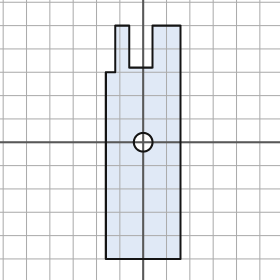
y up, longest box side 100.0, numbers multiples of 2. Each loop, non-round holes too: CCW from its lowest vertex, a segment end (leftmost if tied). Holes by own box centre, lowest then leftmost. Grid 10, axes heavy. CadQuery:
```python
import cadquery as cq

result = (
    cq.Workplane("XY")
    .moveTo(-16.0, -50.0)
    .lineTo(16.0, -50.0)
    .lineTo(16.0, 50.0)
    .lineTo(4.0, 50.0)
    .lineTo(4.0, 32.0)
    .lineTo(-6.0, 32.0)
    .lineTo(-6.0, 50.0)
    .lineTo(-12.0, 50.0)
    .lineTo(-12.0, 30.0)
    .lineTo(-16.0, 30.0)
    .close()
    .moveTo(0.0, 0.0)
    .circle(4.0)
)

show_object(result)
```